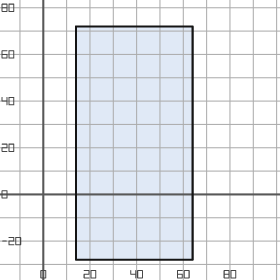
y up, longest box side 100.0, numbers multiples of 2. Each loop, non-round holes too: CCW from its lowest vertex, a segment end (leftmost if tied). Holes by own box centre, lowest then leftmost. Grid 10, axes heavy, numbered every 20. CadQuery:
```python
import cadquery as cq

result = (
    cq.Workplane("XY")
    .moveTo(14.0, -28.0)
    .lineTo(64.0, -28.0)
    .lineTo(64.0, 72.0)
    .lineTo(14.0, 72.0)
    .close()
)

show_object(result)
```